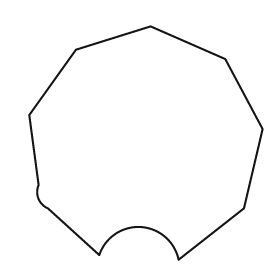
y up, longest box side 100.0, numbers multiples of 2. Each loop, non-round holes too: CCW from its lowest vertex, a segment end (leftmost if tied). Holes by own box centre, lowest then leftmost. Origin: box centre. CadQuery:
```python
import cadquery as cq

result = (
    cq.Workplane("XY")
    .moveTo(14.0, -50.0)
    .lineTo(42.0, -28.0)
    .lineTo(50.0, 6.0)
    .lineTo(34.0, 36.0)
    .lineTo(2.0, 50.0)
    .lineTo(-30.0, 40.0)
    .lineTo(-50.0, 12.0)
    .lineTo(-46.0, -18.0)
    .threePointArc((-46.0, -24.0), (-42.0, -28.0))
    .lineTo(-20.0, -48.0)
    .threePointArc((-2.0, -36.0), (14.0, -50.0))
    .close()
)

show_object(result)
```